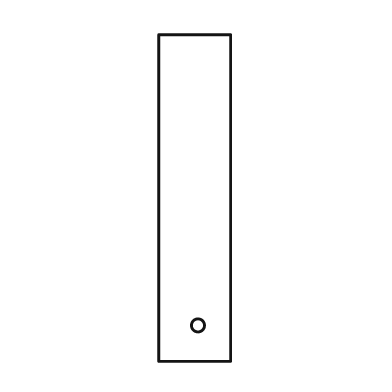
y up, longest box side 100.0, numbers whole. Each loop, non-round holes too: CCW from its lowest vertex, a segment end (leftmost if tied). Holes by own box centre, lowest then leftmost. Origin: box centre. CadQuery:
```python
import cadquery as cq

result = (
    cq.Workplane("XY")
    .moveTo(-11.0, -50.0)
    .lineTo(11.0, -50.0)
    .lineTo(11.0, 50.0)
    .lineTo(-11.0, 50.0)
    .close()
    .moveTo(1.0, -39.0)
    .circle(2.0)
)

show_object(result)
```